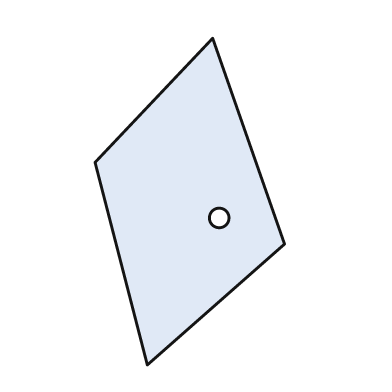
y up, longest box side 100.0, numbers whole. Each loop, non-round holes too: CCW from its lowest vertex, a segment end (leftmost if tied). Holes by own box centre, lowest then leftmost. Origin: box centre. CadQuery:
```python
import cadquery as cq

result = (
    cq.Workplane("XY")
    .moveTo(-13.0, -50.0)
    .lineTo(29.0, -13.0)
    .lineTo(7.0, 50.0)
    .lineTo(-29.0, 12.0)
    .close()
    .moveTo(9.0, -5.0)
    .circle(3.0)
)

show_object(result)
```